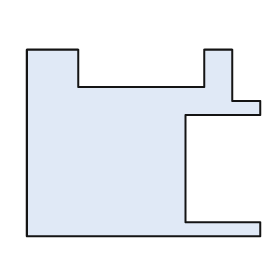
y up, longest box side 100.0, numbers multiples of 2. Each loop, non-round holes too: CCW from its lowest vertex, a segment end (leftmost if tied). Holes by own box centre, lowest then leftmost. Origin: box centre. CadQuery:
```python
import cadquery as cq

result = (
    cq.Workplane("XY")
    .moveTo(-50.0, -40.0)
    .lineTo(50.0, -40.0)
    .lineTo(50.0, -34.0)
    .lineTo(18.0, -34.0)
    .lineTo(18.0, 12.0)
    .lineTo(50.0, 12.0)
    .lineTo(50.0, 18.0)
    .lineTo(38.0, 18.0)
    .lineTo(38.0, 40.0)
    .lineTo(26.0, 40.0)
    .lineTo(26.0, 24.0)
    .lineTo(-28.0, 24.0)
    .lineTo(-28.0, 40.0)
    .lineTo(-50.0, 40.0)
    .close()
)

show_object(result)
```